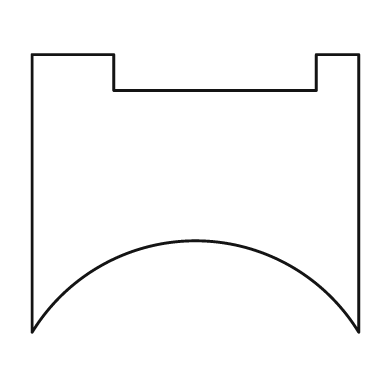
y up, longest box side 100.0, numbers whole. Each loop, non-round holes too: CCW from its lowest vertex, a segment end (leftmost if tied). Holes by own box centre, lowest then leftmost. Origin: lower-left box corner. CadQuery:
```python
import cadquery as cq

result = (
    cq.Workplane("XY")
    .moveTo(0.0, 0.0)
    .threePointArc((50.0, 28.0), (100.0, 0.0))
    .lineTo(100.0, 85.0)
    .lineTo(87.0, 85.0)
    .lineTo(87.0, 74.0)
    .lineTo(25.0, 74.0)
    .lineTo(25.0, 85.0)
    .lineTo(0.0, 85.0)
    .close()
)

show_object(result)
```